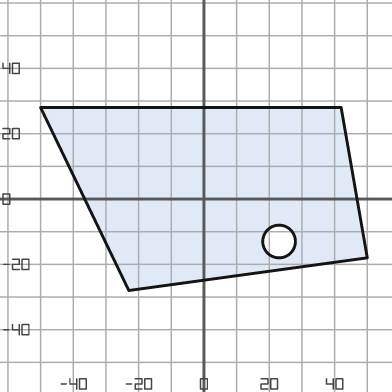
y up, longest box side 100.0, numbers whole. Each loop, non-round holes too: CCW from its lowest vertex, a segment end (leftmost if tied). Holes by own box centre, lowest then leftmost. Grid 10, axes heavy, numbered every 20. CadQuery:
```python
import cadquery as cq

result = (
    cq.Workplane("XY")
    .moveTo(-23.0, -28.0)
    .lineTo(50.0, -18.0)
    .lineTo(42.0, 28.0)
    .lineTo(-50.0, 28.0)
    .close()
    .moveTo(23.0, -13.0)
    .circle(5.0)
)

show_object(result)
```